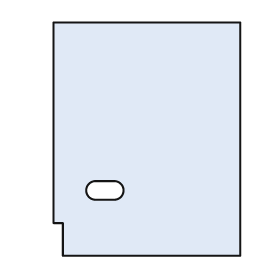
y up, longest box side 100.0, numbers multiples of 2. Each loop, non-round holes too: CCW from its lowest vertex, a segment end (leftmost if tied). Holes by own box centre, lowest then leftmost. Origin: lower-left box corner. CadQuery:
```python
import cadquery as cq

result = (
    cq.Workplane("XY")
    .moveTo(4.0, 0.0)
    .lineTo(80.0, 0.0)
    .lineTo(80.0, 100.0)
    .lineTo(0.0, 100.0)
    .lineTo(0.0, 14.0)
    .lineTo(4.0, 14.0)
    .close()
    .moveTo(18.0, 24.0)
    .lineTo(26.0, 24.0)
    .threePointArc((30.0, 28.0), (26.0, 32.0))
    .lineTo(18.0, 32.0)
    .threePointArc((14.0, 28.0), (18.0, 24.0))
    .close()
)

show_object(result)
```